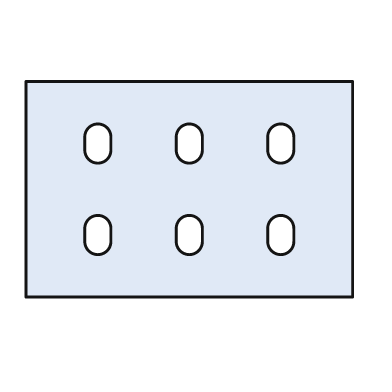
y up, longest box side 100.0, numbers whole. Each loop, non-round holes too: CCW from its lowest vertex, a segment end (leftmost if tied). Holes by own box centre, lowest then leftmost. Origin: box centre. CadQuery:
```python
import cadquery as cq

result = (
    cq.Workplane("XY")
    .moveTo(-50.0, -33.0)
    .lineTo(50.0, -33.0)
    .lineTo(50.0, 33.0)
    .lineTo(-50.0, 33.0)
    .close()
    .moveTo(-32.0, -16.0)
    .threePointArc((-28.0, -20.0), (-24.0, -16.0))
    .lineTo(-24.0, -12.0)
    .threePointArc((-28.0, -8.0), (-32.0, -12.0))
    .close()
    .moveTo(-4.0, -16.0)
    .threePointArc((0.0, -20.0), (4.0, -16.0))
    .lineTo(4.0, -12.0)
    .threePointArc((0.0, -8.0), (-4.0, -12.0))
    .close()
    .moveTo(24.0, -16.0)
    .threePointArc((28.0, -20.0), (32.0, -16.0))
    .lineTo(32.0, -12.0)
    .threePointArc((28.0, -8.0), (24.0, -12.0))
    .close()
    .moveTo(-32.0, 12.0)
    .threePointArc((-28.0, 8.0), (-24.0, 12.0))
    .lineTo(-24.0, 16.0)
    .threePointArc((-28.0, 20.0), (-32.0, 16.0))
    .close()
    .moveTo(-4.0, 12.0)
    .threePointArc((0.0, 8.0), (4.0, 12.0))
    .lineTo(4.0, 16.0)
    .threePointArc((0.0, 20.0), (-4.0, 16.0))
    .close()
    .moveTo(24.0, 12.0)
    .threePointArc((28.0, 8.0), (32.0, 12.0))
    .lineTo(32.0, 16.0)
    .threePointArc((28.0, 20.0), (24.0, 16.0))
    .close()
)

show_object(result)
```